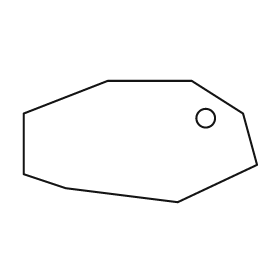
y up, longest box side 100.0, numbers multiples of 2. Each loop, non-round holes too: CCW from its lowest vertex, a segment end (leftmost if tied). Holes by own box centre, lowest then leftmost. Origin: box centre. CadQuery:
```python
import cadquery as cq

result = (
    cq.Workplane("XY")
    .moveTo(16.0, -26.0)
    .lineTo(50.0, -10.0)
    .lineTo(44.0, 12.0)
    .lineTo(22.0, 26.0)
    .lineTo(-14.0, 26.0)
    .lineTo(-50.0, 12.0)
    .lineTo(-50.0, -14.0)
    .lineTo(-32.0, -20.0)
    .close()
    .moveTo(28.0, 10.0)
    .circle(4.0)
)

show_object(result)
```